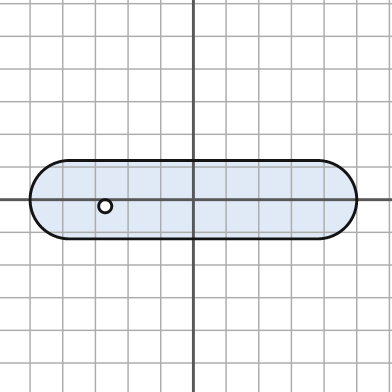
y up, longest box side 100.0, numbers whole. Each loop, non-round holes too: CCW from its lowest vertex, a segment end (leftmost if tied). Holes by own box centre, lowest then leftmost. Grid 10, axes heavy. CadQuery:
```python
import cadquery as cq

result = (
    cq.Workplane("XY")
    .moveTo(-38.0, -12.0)
    .lineTo(38.0, -12.0)
    .threePointArc((50.0, 0.0), (38.0, 12.0))
    .lineTo(-38.0, 12.0)
    .threePointArc((-50.0, 0.0), (-38.0, -12.0))
    .close()
    .moveTo(-27.0, -2.0)
    .circle(2.0)
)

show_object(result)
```